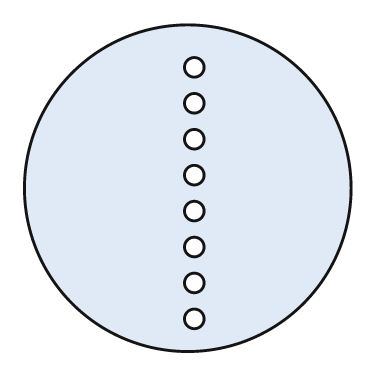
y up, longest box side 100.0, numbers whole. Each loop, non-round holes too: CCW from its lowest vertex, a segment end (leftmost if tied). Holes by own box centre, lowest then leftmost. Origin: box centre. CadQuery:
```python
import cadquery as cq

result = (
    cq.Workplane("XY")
    .moveTo(0.0, 0.0)
    .circle(50.0)
    .moveTo(2.0, -40.0)
    .circle(3.0)
    .moveTo(2.0, -29.0)
    .circle(3.0)
    .moveTo(2.0, -18.0)
    .circle(3.0)
    .moveTo(2.0, -7.0)
    .circle(3.0)
    .moveTo(2.0, 4.0)
    .circle(3.0)
    .moveTo(2.0, 15.0)
    .circle(3.0)
    .moveTo(2.0, 26.0)
    .circle(3.0)
    .moveTo(2.0, 37.0)
    .circle(3.0)
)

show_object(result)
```